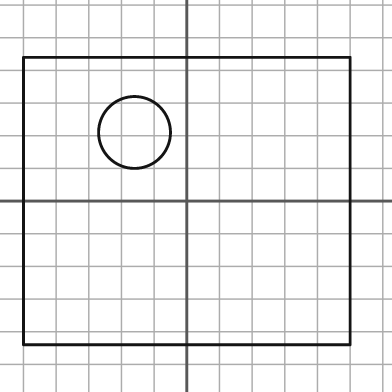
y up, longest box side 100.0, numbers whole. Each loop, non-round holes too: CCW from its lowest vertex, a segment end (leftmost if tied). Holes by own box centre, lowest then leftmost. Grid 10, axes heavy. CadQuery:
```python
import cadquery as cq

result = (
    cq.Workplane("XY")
    .moveTo(-50.0, -44.0)
    .lineTo(50.0, -44.0)
    .lineTo(50.0, 44.0)
    .lineTo(-50.0, 44.0)
    .close()
    .moveTo(-16.0, 21.0)
    .circle(11.0)
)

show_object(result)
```